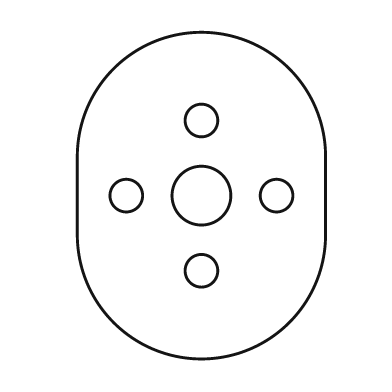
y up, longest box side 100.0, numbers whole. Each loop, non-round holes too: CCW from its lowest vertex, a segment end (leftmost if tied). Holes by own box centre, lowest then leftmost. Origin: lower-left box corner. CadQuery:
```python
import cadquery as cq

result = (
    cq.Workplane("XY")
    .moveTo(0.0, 38.0)
    .threePointArc((38.0, 0.0), (76.0, 38.0))
    .lineTo(76.0, 62.0)
    .threePointArc((38.0, 100.0), (0.0, 62.0))
    .close()
    .moveTo(38.0, 27.0)
    .circle(5.0)
    .moveTo(15.0, 50.0)
    .circle(5.0)
    .moveTo(38.0, 50.0)
    .circle(9.0)
    .moveTo(61.0, 50.0)
    .circle(5.0)
    .moveTo(38.0, 73.0)
    .circle(5.0)
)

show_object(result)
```